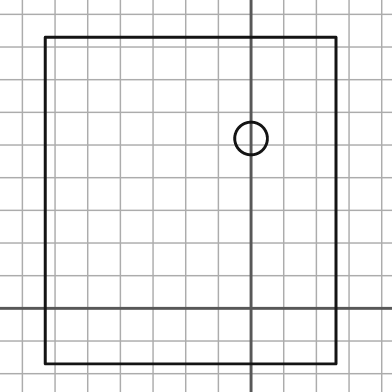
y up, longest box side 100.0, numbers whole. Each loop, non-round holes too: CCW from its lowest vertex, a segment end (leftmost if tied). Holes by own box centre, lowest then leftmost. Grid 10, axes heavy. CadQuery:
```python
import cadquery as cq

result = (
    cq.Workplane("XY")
    .moveTo(-63.0, -17.0)
    .lineTo(26.0, -17.0)
    .lineTo(26.0, 83.0)
    .lineTo(-63.0, 83.0)
    .close()
    .moveTo(0.0, 52.0)
    .circle(5.0)
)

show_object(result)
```